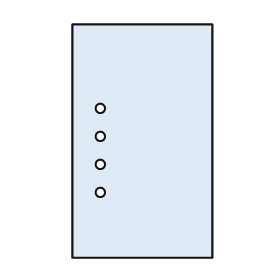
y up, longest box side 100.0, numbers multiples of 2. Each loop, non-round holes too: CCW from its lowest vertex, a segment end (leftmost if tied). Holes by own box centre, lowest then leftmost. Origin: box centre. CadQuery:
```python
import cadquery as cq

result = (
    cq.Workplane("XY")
    .moveTo(-30.0, -50.0)
    .lineTo(30.0, -50.0)
    .lineTo(30.0, 50.0)
    .lineTo(-30.0, 50.0)
    .close()
    .moveTo(-18.0, -22.0)
    .circle(2.0)
    .moveTo(-18.0, -10.0)
    .circle(2.0)
    .moveTo(-18.0, 2.0)
    .circle(2.0)
    .moveTo(-18.0, 14.0)
    .circle(2.0)
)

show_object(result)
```